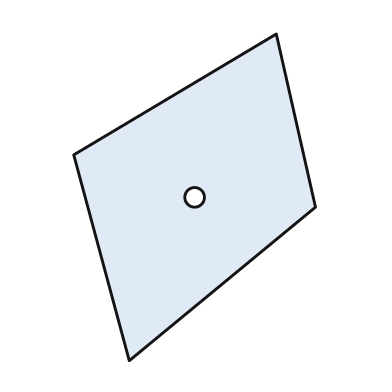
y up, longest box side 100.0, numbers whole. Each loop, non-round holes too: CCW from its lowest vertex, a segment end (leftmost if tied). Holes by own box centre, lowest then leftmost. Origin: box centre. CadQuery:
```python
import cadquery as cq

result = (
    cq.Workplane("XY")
    .moveTo(-20.0, -50.0)
    .lineTo(37.0, -3.0)
    .lineTo(25.0, 50.0)
    .lineTo(-37.0, 13.0)
    .close()
    .moveTo(0.0, 0.0)
    .circle(3.0)
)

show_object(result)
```